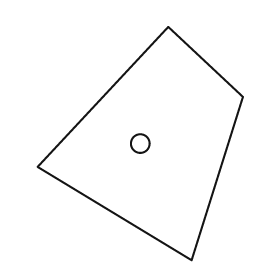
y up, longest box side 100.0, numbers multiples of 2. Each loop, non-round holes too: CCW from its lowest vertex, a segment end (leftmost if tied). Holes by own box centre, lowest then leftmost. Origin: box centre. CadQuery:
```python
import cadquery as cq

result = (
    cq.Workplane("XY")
    .moveTo(22.0, -50.0)
    .lineTo(44.0, 20.0)
    .lineTo(12.0, 50.0)
    .lineTo(-44.0, -10.0)
    .close()
    .moveTo(0.0, 0.0)
    .circle(4.0)
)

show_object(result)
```